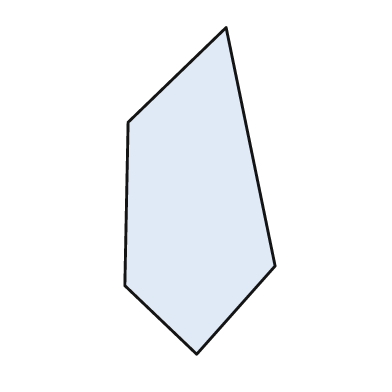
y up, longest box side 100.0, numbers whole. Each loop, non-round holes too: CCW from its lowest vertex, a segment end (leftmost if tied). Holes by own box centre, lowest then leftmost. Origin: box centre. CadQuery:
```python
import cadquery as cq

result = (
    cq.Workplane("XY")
    .moveTo(-1.0, -50.0)
    .lineTo(23.0, -23.0)
    .lineTo(8.0, 50.0)
    .lineTo(-22.0, 21.0)
    .lineTo(-23.0, -29.0)
    .close()
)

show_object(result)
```